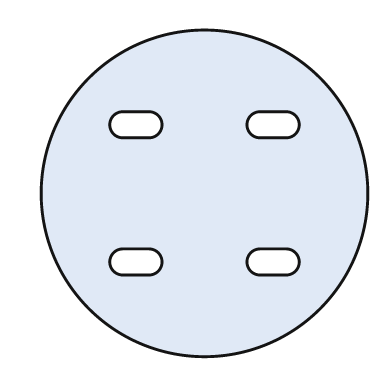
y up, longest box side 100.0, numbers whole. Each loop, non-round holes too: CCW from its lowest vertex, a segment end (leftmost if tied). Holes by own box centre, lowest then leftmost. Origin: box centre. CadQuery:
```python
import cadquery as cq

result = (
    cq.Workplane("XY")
    .moveTo(0.0, 0.0)
    .circle(50.0)
    .moveTo(-25.0, -25.0)
    .lineTo(-17.0, -25.0)
    .threePointArc((-13.0, -21.0), (-17.0, -17.0))
    .lineTo(-25.0, -17.0)
    .threePointArc((-29.0, -21.0), (-25.0, -25.0))
    .close()
    .moveTo(17.0, -25.0)
    .lineTo(25.0, -25.0)
    .threePointArc((29.0, -21.0), (25.0, -17.0))
    .lineTo(17.0, -17.0)
    .threePointArc((13.0, -21.0), (17.0, -25.0))
    .close()
    .moveTo(-25.0, 17.0)
    .lineTo(-17.0, 17.0)
    .threePointArc((-13.0, 21.0), (-17.0, 25.0))
    .lineTo(-25.0, 25.0)
    .threePointArc((-29.0, 21.0), (-25.0, 17.0))
    .close()
    .moveTo(17.0, 17.0)
    .lineTo(25.0, 17.0)
    .threePointArc((29.0, 21.0), (25.0, 25.0))
    .lineTo(17.0, 25.0)
    .threePointArc((13.0, 21.0), (17.0, 17.0))
    .close()
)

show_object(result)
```